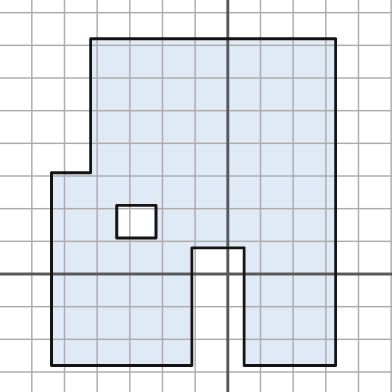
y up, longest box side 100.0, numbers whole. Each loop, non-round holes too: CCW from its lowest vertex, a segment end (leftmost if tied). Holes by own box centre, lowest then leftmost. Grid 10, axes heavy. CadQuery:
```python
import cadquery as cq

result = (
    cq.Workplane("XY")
    .moveTo(-54.0, -28.0)
    .lineTo(-11.0, -28.0)
    .lineTo(-11.0, 8.0)
    .lineTo(5.0, 8.0)
    .lineTo(5.0, -28.0)
    .lineTo(33.0, -28.0)
    .lineTo(33.0, 72.0)
    .lineTo(-42.0, 72.0)
    .lineTo(-42.0, 31.0)
    .lineTo(-54.0, 31.0)
    .close()
    .moveTo(-34.0, 11.0)
    .lineTo(-22.0, 11.0)
    .lineTo(-22.0, 21.0)
    .lineTo(-34.0, 21.0)
    .close()
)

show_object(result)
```